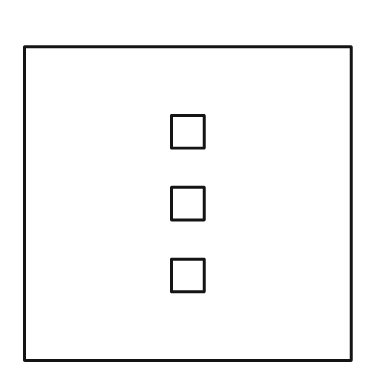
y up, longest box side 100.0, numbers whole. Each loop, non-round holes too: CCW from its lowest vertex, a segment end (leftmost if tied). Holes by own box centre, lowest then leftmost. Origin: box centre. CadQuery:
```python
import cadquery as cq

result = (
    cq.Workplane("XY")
    .moveTo(-50.0, -48.0)
    .lineTo(50.0, -48.0)
    .lineTo(50.0, 48.0)
    .lineTo(-50.0, 48.0)
    .close()
    .moveTo(-5.0, -27.0)
    .lineTo(5.0, -27.0)
    .lineTo(5.0, -17.0)
    .lineTo(-5.0, -17.0)
    .close()
    .moveTo(-5.0, -5.0)
    .lineTo(5.0, -5.0)
    .lineTo(5.0, 5.0)
    .lineTo(-5.0, 5.0)
    .close()
    .moveTo(-5.0, 17.0)
    .lineTo(5.0, 17.0)
    .lineTo(5.0, 27.0)
    .lineTo(-5.0, 27.0)
    .close()
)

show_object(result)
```